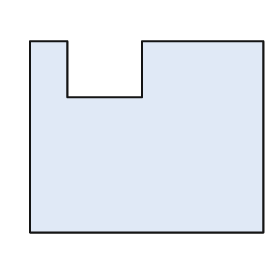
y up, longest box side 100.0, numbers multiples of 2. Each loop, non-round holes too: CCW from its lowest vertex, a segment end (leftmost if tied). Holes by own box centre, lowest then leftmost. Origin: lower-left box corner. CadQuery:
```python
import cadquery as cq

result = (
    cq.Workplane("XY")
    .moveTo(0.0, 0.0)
    .lineTo(100.0, 0.0)
    .lineTo(100.0, 82.0)
    .lineTo(48.0, 82.0)
    .lineTo(48.0, 58.0)
    .lineTo(16.0, 58.0)
    .lineTo(16.0, 82.0)
    .lineTo(0.0, 82.0)
    .close()
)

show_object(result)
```